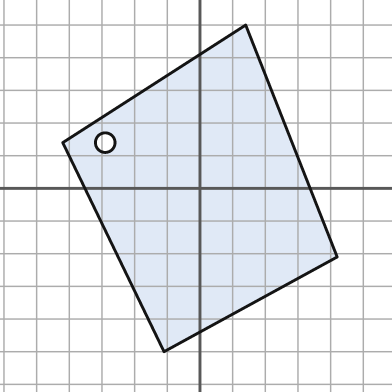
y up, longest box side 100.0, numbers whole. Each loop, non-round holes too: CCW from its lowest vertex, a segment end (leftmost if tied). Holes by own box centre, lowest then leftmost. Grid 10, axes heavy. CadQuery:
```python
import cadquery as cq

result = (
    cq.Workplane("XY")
    .moveTo(-11.0, -50.0)
    .lineTo(42.0, -21.0)
    .lineTo(14.0, 50.0)
    .lineTo(-42.0, 14.0)
    .close()
    .moveTo(-29.0, 14.0)
    .circle(3.0)
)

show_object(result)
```